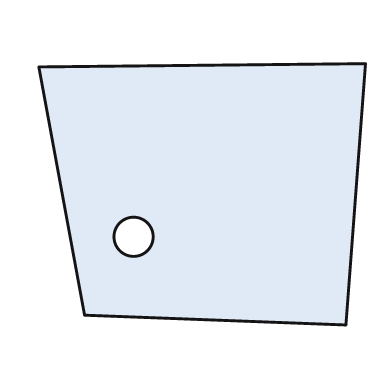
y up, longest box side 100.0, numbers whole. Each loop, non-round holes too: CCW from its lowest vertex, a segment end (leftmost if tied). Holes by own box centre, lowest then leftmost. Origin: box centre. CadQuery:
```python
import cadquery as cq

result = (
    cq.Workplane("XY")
    .moveTo(44.0, -40.0)
    .lineTo(50.0, 40.0)
    .lineTo(-50.0, 39.0)
    .lineTo(-36.0, -37.0)
    .close()
    .moveTo(-21.0, -13.0)
    .circle(6.0)
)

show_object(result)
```